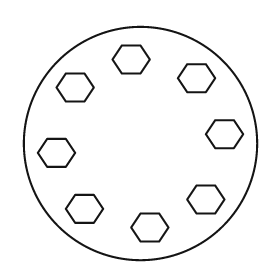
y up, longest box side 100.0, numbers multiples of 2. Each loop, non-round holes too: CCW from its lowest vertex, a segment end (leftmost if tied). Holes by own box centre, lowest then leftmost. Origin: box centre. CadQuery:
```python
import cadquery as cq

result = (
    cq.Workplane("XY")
    .moveTo(0.0, 0.0)
    .circle(50.0)
    .moveTo(0.0, -42.0)
    .lineTo(8.0, -42.0)
    .lineTo(12.0, -36.0)
    .lineTo(8.0, -30.0)
    .lineTo(0.0, -30.0)
    .lineTo(-4.0, -36.0)
    .close()
    .moveTo(-28.0, -34.0)
    .lineTo(-20.0, -34.0)
    .lineTo(-16.0, -28.0)
    .lineTo(-20.0, -22.0)
    .lineTo(-28.0, -22.0)
    .lineTo(-32.0, -28.0)
    .close()
    .moveTo(24.0, -30.0)
    .lineTo(32.0, -30.0)
    .lineTo(36.0, -24.0)
    .lineTo(32.0, -18.0)
    .lineTo(24.0, -18.0)
    .lineTo(20.0, -24.0)
    .close()
    .moveTo(-40.0, -10.0)
    .lineTo(-32.0, -10.0)
    .lineTo(-28.0, -4.0)
    .lineTo(-32.0, 2.0)
    .lineTo(-40.0, 2.0)
    .lineTo(-44.0, -4.0)
    .close()
    .moveTo(32.0, -2.0)
    .lineTo(40.0, -2.0)
    .lineTo(44.0, 4.0)
    .lineTo(40.0, 10.0)
    .lineTo(32.0, 10.0)
    .lineTo(28.0, 4.0)
    .close()
    .moveTo(-32.0, 18.0)
    .lineTo(-24.0, 18.0)
    .lineTo(-20.0, 24.0)
    .lineTo(-24.0, 30.0)
    .lineTo(-32.0, 30.0)
    .lineTo(-36.0, 24.0)
    .close()
    .moveTo(20.0, 22.0)
    .lineTo(28.0, 22.0)
    .lineTo(32.0, 28.0)
    .lineTo(28.0, 34.0)
    .lineTo(20.0, 34.0)
    .lineTo(16.0, 28.0)
    .close()
    .moveTo(-8.0, 30.0)
    .lineTo(0.0, 30.0)
    .lineTo(4.0, 36.0)
    .lineTo(0.0, 42.0)
    .lineTo(-8.0, 42.0)
    .lineTo(-12.0, 36.0)
    .close()
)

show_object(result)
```